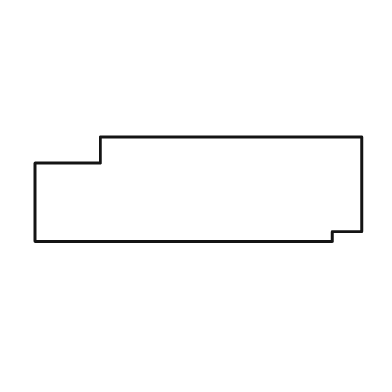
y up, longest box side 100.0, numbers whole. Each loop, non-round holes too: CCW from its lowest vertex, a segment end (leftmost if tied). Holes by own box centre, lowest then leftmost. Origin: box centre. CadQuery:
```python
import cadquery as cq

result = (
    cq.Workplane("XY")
    .moveTo(-50.0, -16.0)
    .lineTo(41.0, -16.0)
    .lineTo(41.0, -13.0)
    .lineTo(50.0, -13.0)
    .lineTo(50.0, 16.0)
    .lineTo(-30.0, 16.0)
    .lineTo(-30.0, 8.0)
    .lineTo(-50.0, 8.0)
    .close()
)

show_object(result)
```